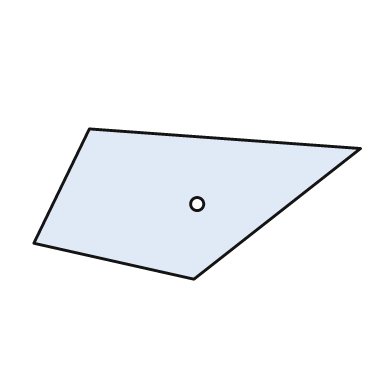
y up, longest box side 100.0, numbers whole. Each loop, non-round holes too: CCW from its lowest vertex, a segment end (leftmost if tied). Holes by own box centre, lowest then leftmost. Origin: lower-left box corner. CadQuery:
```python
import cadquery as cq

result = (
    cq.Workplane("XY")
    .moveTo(49.0, 0.0)
    .lineTo(100.0, 40.0)
    .lineTo(17.0, 46.0)
    .lineTo(0.0, 11.0)
    .close()
    .moveTo(50.0, 23.0)
    .circle(2.0)
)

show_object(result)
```